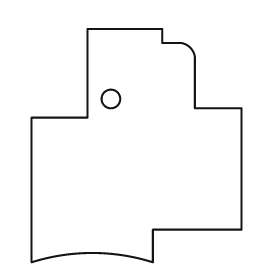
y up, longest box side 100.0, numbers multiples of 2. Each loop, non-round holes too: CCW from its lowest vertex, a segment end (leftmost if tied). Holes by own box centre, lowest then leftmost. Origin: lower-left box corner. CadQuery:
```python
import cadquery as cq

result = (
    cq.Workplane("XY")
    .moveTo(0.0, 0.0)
    .threePointArc((26.0, 4.0), (52.0, 0.0))
    .lineTo(52.0, 14.0)
    .lineTo(90.0, 14.0)
    .lineTo(90.0, 66.0)
    .lineTo(70.0, 66.0)
    .lineTo(70.0, 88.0)
    .threePointArc((68.0, 92.0), (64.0, 94.0))
    .lineTo(56.0, 94.0)
    .lineTo(56.0, 100.0)
    .lineTo(24.0, 100.0)
    .lineTo(24.0, 62.0)
    .lineTo(0.0, 62.0)
    .close()
    .moveTo(34.0, 70.0)
    .circle(4.0)
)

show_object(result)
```